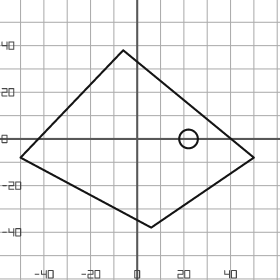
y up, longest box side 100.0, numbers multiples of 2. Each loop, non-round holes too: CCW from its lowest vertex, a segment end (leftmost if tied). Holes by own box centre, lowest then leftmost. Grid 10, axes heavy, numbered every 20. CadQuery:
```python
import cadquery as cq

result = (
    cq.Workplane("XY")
    .moveTo(6.0, -38.0)
    .lineTo(50.0, -8.0)
    .lineTo(-6.0, 38.0)
    .lineTo(-50.0, -8.0)
    .close()
    .moveTo(22.0, 0.0)
    .circle(4.0)
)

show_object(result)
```